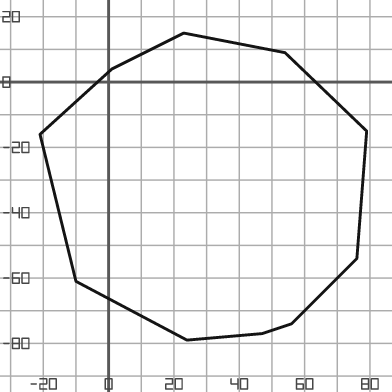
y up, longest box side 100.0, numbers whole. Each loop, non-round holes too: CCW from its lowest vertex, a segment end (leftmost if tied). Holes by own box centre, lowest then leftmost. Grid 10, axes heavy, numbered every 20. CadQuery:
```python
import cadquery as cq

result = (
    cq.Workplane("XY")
    .moveTo(24.0, -79.0)
    .lineTo(47.0, -77.0)
    .lineTo(56.0, -74.0)
    .lineTo(76.0, -54.0)
    .lineTo(79.0, -15.0)
    .lineTo(54.0, 9.0)
    .lineTo(23.0, 15.0)
    .lineTo(1.0, 4.0)
    .lineTo(-21.0, -16.0)
    .lineTo(-10.0, -61.0)
    .close()
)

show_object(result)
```